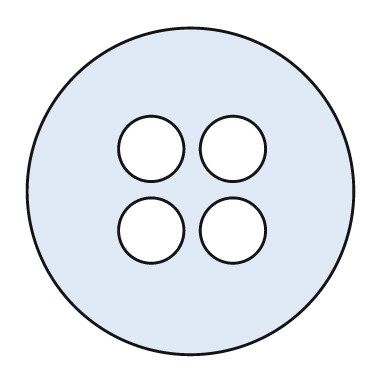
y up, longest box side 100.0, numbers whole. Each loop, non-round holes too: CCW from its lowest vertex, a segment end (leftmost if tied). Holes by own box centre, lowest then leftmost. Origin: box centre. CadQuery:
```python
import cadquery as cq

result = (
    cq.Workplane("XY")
    .moveTo(0.0, 0.0)
    .circle(50.0)
    .moveTo(-12.0, -12.0)
    .circle(10.0)
    .moveTo(13.0, -12.0)
    .circle(10.0)
    .moveTo(-12.0, 13.0)
    .circle(10.0)
    .moveTo(13.0, 13.0)
    .circle(10.0)
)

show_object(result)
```